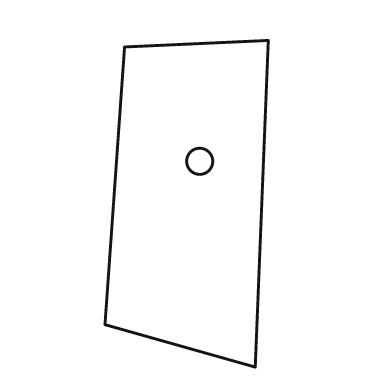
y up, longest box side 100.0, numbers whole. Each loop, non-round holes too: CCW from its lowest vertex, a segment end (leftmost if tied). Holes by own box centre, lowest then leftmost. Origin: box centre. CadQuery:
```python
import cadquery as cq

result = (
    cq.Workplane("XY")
    .moveTo(21.0, -50.0)
    .lineTo(25.0, 50.0)
    .lineTo(-19.0, 48.0)
    .lineTo(-25.0, -37.0)
    .close()
    .moveTo(4.0, 13.0)
    .circle(4.0)
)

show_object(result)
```